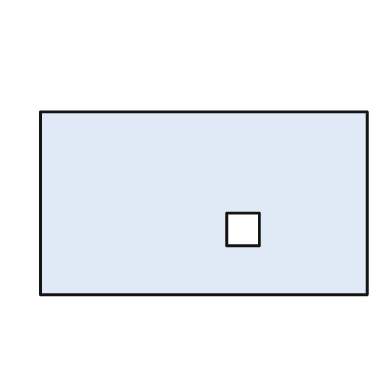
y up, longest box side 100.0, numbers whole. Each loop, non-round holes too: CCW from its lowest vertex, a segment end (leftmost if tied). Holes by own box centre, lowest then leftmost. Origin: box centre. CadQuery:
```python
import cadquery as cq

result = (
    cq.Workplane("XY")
    .moveTo(-50.0, -28.0)
    .lineTo(50.0, -28.0)
    .lineTo(50.0, 28.0)
    .lineTo(-50.0, 28.0)
    .close()
    .moveTo(7.0, -13.0)
    .lineTo(17.0, -13.0)
    .lineTo(17.0, -3.0)
    .lineTo(7.0, -3.0)
    .close()
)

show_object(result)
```